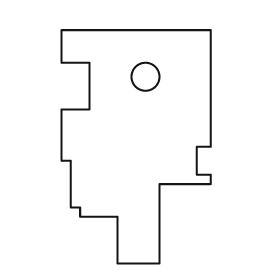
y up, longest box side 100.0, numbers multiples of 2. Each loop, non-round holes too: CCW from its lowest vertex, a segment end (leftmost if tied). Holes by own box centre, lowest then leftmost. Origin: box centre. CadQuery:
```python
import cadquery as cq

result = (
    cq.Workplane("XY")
    .moveTo(-8.0, -50.0)
    .lineTo(10.0, -50.0)
    .lineTo(10.0, -16.0)
    .lineTo(32.0, -16.0)
    .lineTo(32.0, -12.0)
    .lineTo(26.0, -12.0)
    .lineTo(26.0, 0.0)
    .lineTo(32.0, 0.0)
    .lineTo(32.0, 50.0)
    .lineTo(-32.0, 50.0)
    .lineTo(-32.0, 36.0)
    .lineTo(-20.0, 36.0)
    .lineTo(-20.0, 16.0)
    .lineTo(-32.0, 16.0)
    .lineTo(-32.0, -6.0)
    .lineTo(-28.0, -6.0)
    .lineTo(-28.0, -26.0)
    .lineTo(-24.0, -26.0)
    .lineTo(-24.0, -30.0)
    .lineTo(-8.0, -30.0)
    .close()
    .moveTo(4.0, 30.0)
    .circle(6.0)
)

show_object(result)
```